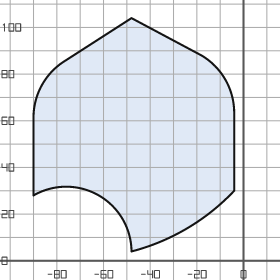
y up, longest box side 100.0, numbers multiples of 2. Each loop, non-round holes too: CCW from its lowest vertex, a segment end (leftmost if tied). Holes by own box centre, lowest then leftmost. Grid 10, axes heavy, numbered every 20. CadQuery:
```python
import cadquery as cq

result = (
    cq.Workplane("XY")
    .moveTo(-48.0, 4.0)
    .threePointArc((-24.0, 14.0), (-4.0, 30.0))
    .lineTo(-4.0, 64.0)
    .threePointArc((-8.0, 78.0), (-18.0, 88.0))
    .lineTo(-48.0, 104.0)
    .lineTo(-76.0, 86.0)
    .threePointArc((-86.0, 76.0), (-90.0, 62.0))
    .lineTo(-90.0, 28.0)
    .threePointArc((-62.0, 28.0), (-48.0, 4.0))
    .close()
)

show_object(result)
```